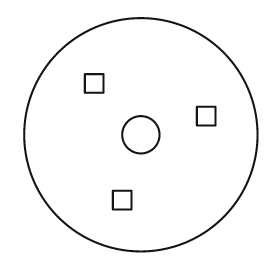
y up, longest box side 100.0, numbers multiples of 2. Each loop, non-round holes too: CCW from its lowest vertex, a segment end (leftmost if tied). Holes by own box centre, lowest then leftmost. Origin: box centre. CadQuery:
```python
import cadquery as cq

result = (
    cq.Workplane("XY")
    .moveTo(0.0, 0.0)
    .circle(50.0)
    .moveTo(-12.0, -32.0)
    .lineTo(-4.0, -32.0)
    .lineTo(-4.0, -24.0)
    .lineTo(-12.0, -24.0)
    .close()
    .moveTo(0.0, 0.0)
    .circle(8.0)
    .moveTo(24.0, 4.0)
    .lineTo(32.0, 4.0)
    .lineTo(32.0, 12.0)
    .lineTo(24.0, 12.0)
    .close()
    .moveTo(-24.0, 18.0)
    .lineTo(-16.0, 18.0)
    .lineTo(-16.0, 26.0)
    .lineTo(-24.0, 26.0)
    .close()
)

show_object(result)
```